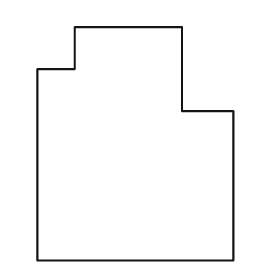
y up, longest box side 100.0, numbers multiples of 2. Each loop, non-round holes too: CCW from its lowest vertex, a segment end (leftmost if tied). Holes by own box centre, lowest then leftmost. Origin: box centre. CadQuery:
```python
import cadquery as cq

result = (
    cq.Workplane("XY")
    .moveTo(-42.0, -50.0)
    .lineTo(42.0, -50.0)
    .lineTo(42.0, 14.0)
    .lineTo(20.0, 14.0)
    .lineTo(20.0, 50.0)
    .lineTo(-26.0, 50.0)
    .lineTo(-26.0, 32.0)
    .lineTo(-42.0, 32.0)
    .close()
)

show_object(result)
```